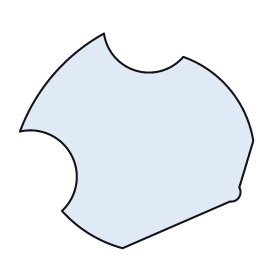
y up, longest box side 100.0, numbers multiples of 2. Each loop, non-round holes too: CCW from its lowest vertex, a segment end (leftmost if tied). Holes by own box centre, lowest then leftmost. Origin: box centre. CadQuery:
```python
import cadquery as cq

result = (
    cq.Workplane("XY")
    .moveTo(-6.0, -46.0)
    .lineTo(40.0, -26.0)
    .threePointArc((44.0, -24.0), (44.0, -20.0))
    .lineTo(50.0, 0.0)
    .threePointArc((40.0, 22.0), (20.0, 36.0))
    .threePointArc((0.0, 30.0), (-14.0, 46.0))
    .threePointArc((-36.0, 28.0), (-50.0, 4.0))
    .threePointArc((-28.0, -6.0), (-32.0, -30.0))
    .threePointArc((-20.0, -40.0), (-6.0, -46.0))
    .close()
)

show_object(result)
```